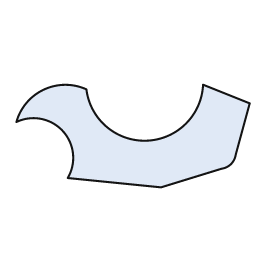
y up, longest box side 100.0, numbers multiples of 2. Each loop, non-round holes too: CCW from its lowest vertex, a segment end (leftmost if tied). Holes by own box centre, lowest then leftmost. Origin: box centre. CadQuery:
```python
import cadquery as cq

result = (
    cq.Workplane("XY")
    .moveTo(12.0, -22.0)
    .lineTo(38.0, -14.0)
    .threePointArc((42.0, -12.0), (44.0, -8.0))
    .lineTo(50.0, 14.0)
    .lineTo(30.0, 22.0)
    .threePointArc((6.0, -2.0), (-20.0, 20.0))
    .threePointArc((-38.0, 20.0), (-50.0, 6.0))
    .threePointArc((-30.0, 2.0), (-28.0, -18.0))
    .close()
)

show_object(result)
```